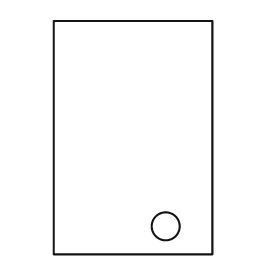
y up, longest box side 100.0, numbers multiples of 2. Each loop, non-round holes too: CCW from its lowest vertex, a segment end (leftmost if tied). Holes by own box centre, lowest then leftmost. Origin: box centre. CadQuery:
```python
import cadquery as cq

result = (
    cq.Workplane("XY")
    .moveTo(-34.0, -50.0)
    .lineTo(34.0, -50.0)
    .lineTo(34.0, 50.0)
    .lineTo(-34.0, 50.0)
    .close()
    .moveTo(14.0, -38.0)
    .circle(6.0)
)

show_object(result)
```